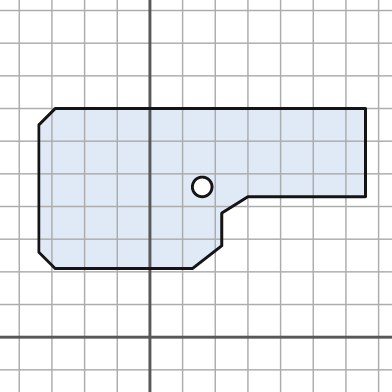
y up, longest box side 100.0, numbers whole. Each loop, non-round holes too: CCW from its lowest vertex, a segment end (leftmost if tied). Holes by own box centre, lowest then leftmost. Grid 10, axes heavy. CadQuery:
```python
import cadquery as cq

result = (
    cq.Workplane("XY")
    .moveTo(-29.0, 21.0)
    .lineTo(13.0, 21.0)
    .lineTo(22.0, 28.0)
    .lineTo(22.0, 38.0)
    .lineTo(30.0, 43.0)
    .lineTo(66.0, 43.0)
    .lineTo(66.0, 70.0)
    .lineTo(-29.0, 70.0)
    .lineTo(-34.0, 65.0)
    .lineTo(-34.0, 26.0)
    .close()
    .moveTo(16.0, 46.0)
    .circle(3.0)
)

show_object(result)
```